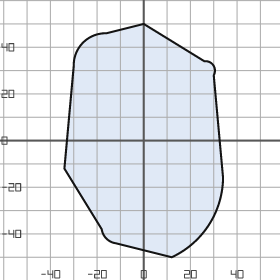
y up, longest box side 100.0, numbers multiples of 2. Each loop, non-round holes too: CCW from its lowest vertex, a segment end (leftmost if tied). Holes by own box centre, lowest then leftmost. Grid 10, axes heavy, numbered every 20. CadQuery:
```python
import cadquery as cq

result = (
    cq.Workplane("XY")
    .moveTo(12.0, -50.0)
    .threePointArc((28.0, -36.0), (34.0, -16.0))
    .lineTo(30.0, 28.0)
    .threePointArc((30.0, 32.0), (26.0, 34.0))
    .lineTo(0.0, 50.0)
    .lineTo(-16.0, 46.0)
    .threePointArc((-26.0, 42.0), (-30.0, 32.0))
    .lineTo(-34.0, -12.0)
    .lineTo(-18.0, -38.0)
    .threePointArc((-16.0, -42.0), (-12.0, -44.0))
    .close()
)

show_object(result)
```